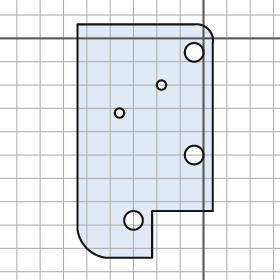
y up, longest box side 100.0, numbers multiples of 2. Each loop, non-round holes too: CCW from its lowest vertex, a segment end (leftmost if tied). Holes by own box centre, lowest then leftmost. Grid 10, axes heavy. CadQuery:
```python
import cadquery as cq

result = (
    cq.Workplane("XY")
    .moveTo(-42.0, -94.0)
    .lineTo(-22.0, -94.0)
    .lineTo(-22.0, -74.0)
    .lineTo(4.0, -74.0)
    .lineTo(4.0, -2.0)
    .threePointArc((2.0, 4.0), (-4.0, 6.0))
    .lineTo(-54.0, 6.0)
    .lineTo(-54.0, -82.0)
    .threePointArc((-50.0, -90.0), (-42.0, -94.0))
    .close()
    .moveTo(-30.0, -78.0)
    .circle(4.0)
    .moveTo(-4.0, -50.0)
    .circle(4.0)
    .moveTo(-36.0, -32.0)
    .circle(2.0)
    .moveTo(-18.0, -20.0)
    .circle(2.0)
    .moveTo(-4.0, -6.0)
    .circle(4.0)
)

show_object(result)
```